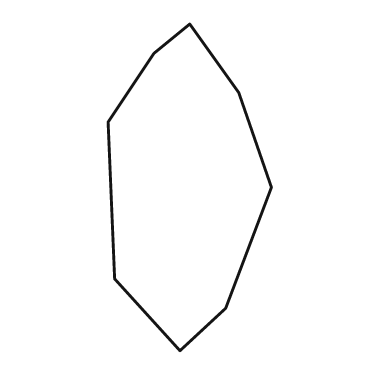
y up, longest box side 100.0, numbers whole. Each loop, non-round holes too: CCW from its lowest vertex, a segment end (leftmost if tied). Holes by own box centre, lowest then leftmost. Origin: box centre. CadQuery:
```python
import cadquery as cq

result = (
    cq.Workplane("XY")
    .moveTo(-3.0, -50.0)
    .lineTo(11.0, -37.0)
    .lineTo(25.0, 0.0)
    .lineTo(15.0, 29.0)
    .lineTo(0.0, 50.0)
    .lineTo(-11.0, 41.0)
    .lineTo(-25.0, 20.0)
    .lineTo(-23.0, -28.0)
    .close()
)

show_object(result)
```